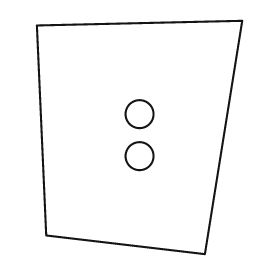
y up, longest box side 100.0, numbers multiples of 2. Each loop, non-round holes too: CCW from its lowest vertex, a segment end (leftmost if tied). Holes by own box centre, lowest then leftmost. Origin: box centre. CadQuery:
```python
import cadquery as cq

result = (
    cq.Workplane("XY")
    .moveTo(28.0, -50.0)
    .lineTo(44.0, 50.0)
    .lineTo(-44.0, 48.0)
    .lineTo(-40.0, -42.0)
    .close()
    .moveTo(0.0, -8.0)
    .circle(6.0)
    .moveTo(0.0, 10.0)
    .circle(6.0)
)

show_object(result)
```